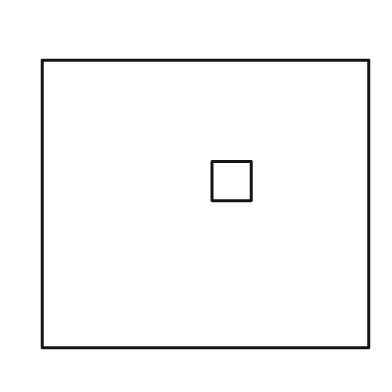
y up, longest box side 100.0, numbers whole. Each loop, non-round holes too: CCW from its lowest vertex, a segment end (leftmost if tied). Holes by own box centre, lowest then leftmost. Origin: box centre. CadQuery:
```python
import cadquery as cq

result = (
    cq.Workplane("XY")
    .moveTo(-50.0, -44.0)
    .lineTo(50.0, -44.0)
    .lineTo(50.0, 44.0)
    .lineTo(-50.0, 44.0)
    .close()
    .moveTo(2.0, 1.0)
    .lineTo(14.0, 1.0)
    .lineTo(14.0, 13.0)
    .lineTo(2.0, 13.0)
    .close()
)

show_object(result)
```